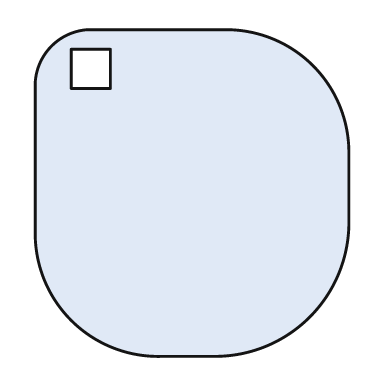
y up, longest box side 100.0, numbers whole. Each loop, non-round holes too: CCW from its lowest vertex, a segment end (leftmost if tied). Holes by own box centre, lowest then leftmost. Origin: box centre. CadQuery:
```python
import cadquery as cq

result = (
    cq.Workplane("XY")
    .moveTo(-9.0, -50.0)
    .lineTo(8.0, -50.0)
    .threePointArc((36.0, -38.0), (48.0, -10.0))
    .lineTo(48.0, 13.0)
    .threePointArc((37.0, 39.0), (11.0, 50.0))
    .lineTo(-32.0, 50.0)
    .threePointArc((-43.0, 45.0), (-48.0, 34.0))
    .lineTo(-48.0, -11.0)
    .threePointArc((-37.0, -39.0), (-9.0, -50.0))
    .close()
    .moveTo(-37.0, 32.0)
    .lineTo(-25.0, 32.0)
    .lineTo(-25.0, 44.0)
    .lineTo(-37.0, 44.0)
    .close()
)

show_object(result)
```